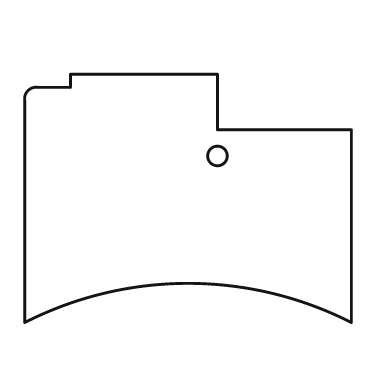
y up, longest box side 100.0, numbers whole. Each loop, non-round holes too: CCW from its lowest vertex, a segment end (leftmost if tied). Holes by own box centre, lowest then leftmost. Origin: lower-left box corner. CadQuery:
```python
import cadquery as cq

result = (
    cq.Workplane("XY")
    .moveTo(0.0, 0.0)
    .threePointArc((50.0, 12.0), (100.0, 0.0))
    .lineTo(100.0, 59.0)
    .lineTo(59.0, 59.0)
    .lineTo(59.0, 76.0)
    .lineTo(14.0, 76.0)
    .lineTo(14.0, 72.0)
    .lineTo(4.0, 72.0)
    .threePointArc((1.0, 71.0), (0.0, 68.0))
    .close()
    .moveTo(59.0, 51.0)
    .circle(3.0)
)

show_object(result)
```